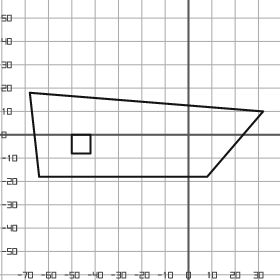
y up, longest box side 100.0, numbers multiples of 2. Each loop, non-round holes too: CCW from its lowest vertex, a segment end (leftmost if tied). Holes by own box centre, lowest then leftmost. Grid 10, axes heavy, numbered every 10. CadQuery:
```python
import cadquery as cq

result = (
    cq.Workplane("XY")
    .moveTo(-64.0, -18.0)
    .lineTo(8.0, -18.0)
    .lineTo(32.0, 10.0)
    .lineTo(-68.0, 18.0)
    .close()
    .moveTo(-50.0, -8.0)
    .lineTo(-42.0, -8.0)
    .lineTo(-42.0, 0.0)
    .lineTo(-50.0, 0.0)
    .close()
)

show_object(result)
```